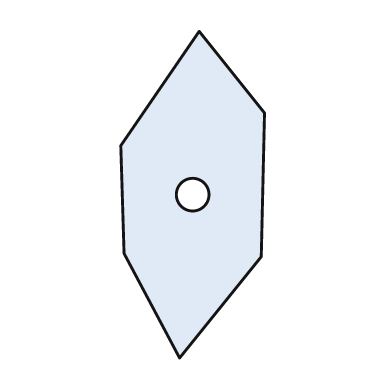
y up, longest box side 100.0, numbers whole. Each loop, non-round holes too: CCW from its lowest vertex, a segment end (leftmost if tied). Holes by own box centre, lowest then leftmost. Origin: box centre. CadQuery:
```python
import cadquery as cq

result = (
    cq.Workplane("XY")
    .moveTo(-4.0, -50.0)
    .lineTo(21.0, -19.0)
    .lineTo(22.0, 25.0)
    .lineTo(2.0, 50.0)
    .lineTo(-22.0, 15.0)
    .lineTo(-21.0, -18.0)
    .close()
    .moveTo(0.0, 0.0)
    .circle(5.0)
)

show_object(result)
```